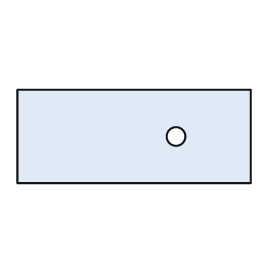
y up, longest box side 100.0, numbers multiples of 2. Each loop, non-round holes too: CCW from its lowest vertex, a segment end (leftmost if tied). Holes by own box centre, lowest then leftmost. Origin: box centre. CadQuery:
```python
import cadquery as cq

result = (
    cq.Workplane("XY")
    .moveTo(-50.0, -20.0)
    .lineTo(50.0, -20.0)
    .lineTo(50.0, 20.0)
    .lineTo(-50.0, 20.0)
    .close()
    .moveTo(18.0, 0.0)
    .circle(4.0)
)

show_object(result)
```